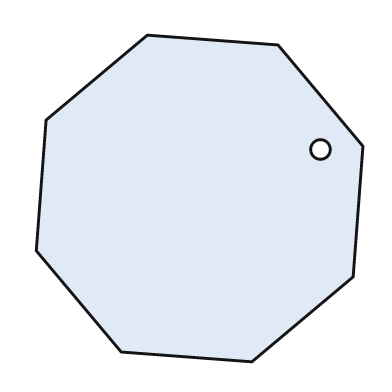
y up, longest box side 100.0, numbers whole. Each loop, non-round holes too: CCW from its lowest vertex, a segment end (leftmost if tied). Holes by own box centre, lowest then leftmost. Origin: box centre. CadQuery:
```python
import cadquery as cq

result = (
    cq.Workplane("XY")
    .moveTo(16.0, -50.0)
    .lineTo(47.0, -24.0)
    .lineTo(50.0, 16.0)
    .lineTo(24.0, 47.0)
    .lineTo(-16.0, 50.0)
    .lineTo(-47.0, 24.0)
    .lineTo(-50.0, -16.0)
    .lineTo(-24.0, -47.0)
    .close()
    .moveTo(37.0, 15.0)
    .circle(3.0)
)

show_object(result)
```